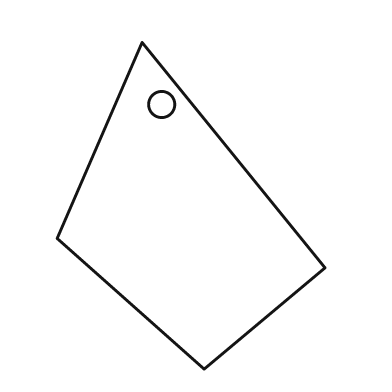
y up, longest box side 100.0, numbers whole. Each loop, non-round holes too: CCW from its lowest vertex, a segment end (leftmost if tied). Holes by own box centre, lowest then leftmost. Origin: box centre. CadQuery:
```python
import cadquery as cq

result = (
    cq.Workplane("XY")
    .moveTo(4.0, -50.0)
    .lineTo(41.0, -19.0)
    .lineTo(-15.0, 50.0)
    .lineTo(-41.0, -10.0)
    .close()
    .moveTo(-9.0, 31.0)
    .circle(4.0)
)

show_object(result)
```